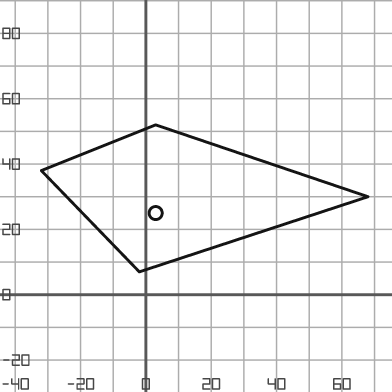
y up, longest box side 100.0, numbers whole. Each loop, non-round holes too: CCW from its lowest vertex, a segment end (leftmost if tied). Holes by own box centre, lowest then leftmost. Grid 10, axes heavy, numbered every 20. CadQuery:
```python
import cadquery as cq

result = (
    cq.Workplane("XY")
    .moveTo(-2.0, 7.0)
    .lineTo(68.0, 30.0)
    .lineTo(3.0, 52.0)
    .lineTo(-32.0, 38.0)
    .close()
    .moveTo(3.0, 25.0)
    .circle(2.0)
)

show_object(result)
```